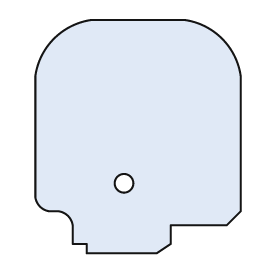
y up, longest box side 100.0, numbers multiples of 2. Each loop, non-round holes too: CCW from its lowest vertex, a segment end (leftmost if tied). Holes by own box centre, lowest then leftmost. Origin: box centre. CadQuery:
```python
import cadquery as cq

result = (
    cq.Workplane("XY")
    .moveTo(-22.0, -50.0)
    .lineTo(8.0, -50.0)
    .lineTo(14.0, -46.0)
    .lineTo(14.0, -38.0)
    .lineTo(38.0, -38.0)
    .lineTo(44.0, -32.0)
    .lineTo(44.0, 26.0)
    .threePointArc((36.0, 42.0), (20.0, 50.0))
    .lineTo(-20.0, 50.0)
    .threePointArc((-36.0, 42.0), (-44.0, 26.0))
    .lineTo(-44.0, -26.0)
    .threePointArc((-42.0, -30.0), (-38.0, -32.0))
    .lineTo(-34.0, -32.0)
    .threePointArc((-30.0, -34.0), (-28.0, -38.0))
    .lineTo(-28.0, -46.0)
    .lineTo(-22.0, -46.0)
    .close()
    .moveTo(-6.0, -20.0)
    .circle(4.0)
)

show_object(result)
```